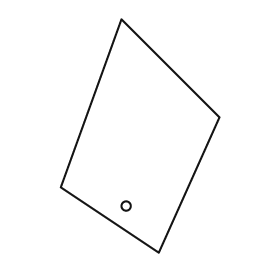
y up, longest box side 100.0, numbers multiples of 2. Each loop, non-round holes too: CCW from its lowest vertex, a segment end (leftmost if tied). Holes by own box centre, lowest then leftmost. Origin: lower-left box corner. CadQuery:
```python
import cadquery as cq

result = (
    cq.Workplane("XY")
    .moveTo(42.0, 0.0)
    .lineTo(68.0, 58.0)
    .lineTo(26.0, 100.0)
    .lineTo(0.0, 28.0)
    .close()
    .moveTo(28.0, 20.0)
    .circle(2.0)
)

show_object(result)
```